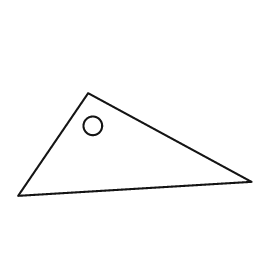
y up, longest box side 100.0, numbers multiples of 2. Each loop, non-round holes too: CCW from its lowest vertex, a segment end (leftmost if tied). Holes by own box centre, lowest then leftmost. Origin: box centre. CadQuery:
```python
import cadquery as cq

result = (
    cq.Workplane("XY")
    .moveTo(-50.0, -22.0)
    .lineTo(50.0, -16.0)
    .lineTo(-20.0, 22.0)
    .close()
    .moveTo(-18.0, 8.0)
    .circle(4.0)
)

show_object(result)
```